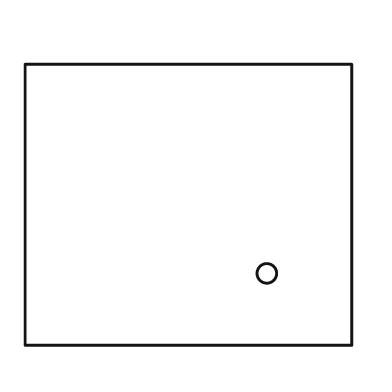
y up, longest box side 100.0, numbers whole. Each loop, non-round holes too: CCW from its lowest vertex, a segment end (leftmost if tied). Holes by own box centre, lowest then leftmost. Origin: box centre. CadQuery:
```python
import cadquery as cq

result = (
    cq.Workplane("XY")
    .moveTo(-50.0, -43.0)
    .lineTo(50.0, -43.0)
    .lineTo(50.0, 43.0)
    .lineTo(-50.0, 43.0)
    .close()
    .moveTo(24.0, -21.0)
    .circle(3.0)
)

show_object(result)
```